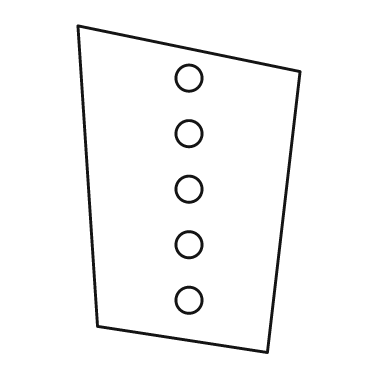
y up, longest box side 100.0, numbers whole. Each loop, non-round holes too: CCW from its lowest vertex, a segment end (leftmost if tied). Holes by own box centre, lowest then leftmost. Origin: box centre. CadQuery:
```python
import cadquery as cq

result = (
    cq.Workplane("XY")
    .moveTo(24.0, -50.0)
    .lineTo(34.0, 36.0)
    .lineTo(-34.0, 50.0)
    .lineTo(-28.0, -42.0)
    .close()
    .moveTo(0.0, -34.0)
    .circle(4.0)
    .moveTo(0.0, -17.0)
    .circle(4.0)
    .moveTo(0.0, 0.0)
    .circle(4.0)
    .moveTo(0.0, 17.0)
    .circle(4.0)
    .moveTo(0.0, 34.0)
    .circle(4.0)
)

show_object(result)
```